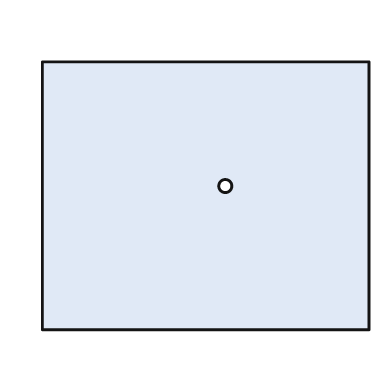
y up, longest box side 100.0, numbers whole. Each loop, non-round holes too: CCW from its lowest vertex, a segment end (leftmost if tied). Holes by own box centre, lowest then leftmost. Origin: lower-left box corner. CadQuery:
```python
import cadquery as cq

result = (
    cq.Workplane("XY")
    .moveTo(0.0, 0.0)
    .lineTo(100.0, 0.0)
    .lineTo(100.0, 82.0)
    .lineTo(0.0, 82.0)
    .close()
    .moveTo(56.0, 44.0)
    .circle(2.0)
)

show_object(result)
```